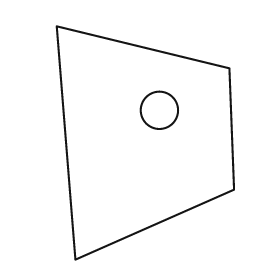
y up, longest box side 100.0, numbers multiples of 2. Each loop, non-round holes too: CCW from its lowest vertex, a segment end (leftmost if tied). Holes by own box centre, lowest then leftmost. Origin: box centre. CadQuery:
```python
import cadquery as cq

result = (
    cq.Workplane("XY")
    .moveTo(-30.0, -50.0)
    .lineTo(38.0, -20.0)
    .lineTo(36.0, 32.0)
    .lineTo(-38.0, 50.0)
    .close()
    .moveTo(6.0, 14.0)
    .circle(8.0)
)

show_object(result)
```